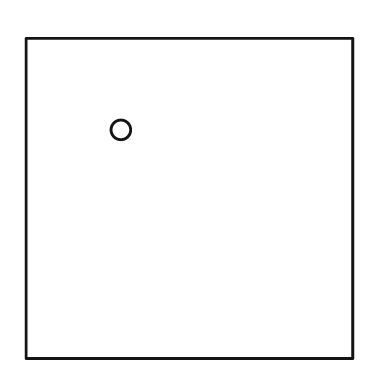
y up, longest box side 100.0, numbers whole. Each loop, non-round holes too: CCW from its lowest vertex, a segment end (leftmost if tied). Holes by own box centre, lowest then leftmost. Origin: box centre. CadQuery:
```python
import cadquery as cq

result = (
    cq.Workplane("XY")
    .moveTo(-50.0, -49.0)
    .lineTo(50.0, -49.0)
    .lineTo(50.0, 49.0)
    .lineTo(-50.0, 49.0)
    .close()
    .moveTo(-21.0, 21.0)
    .circle(3.0)
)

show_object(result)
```